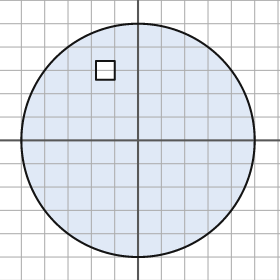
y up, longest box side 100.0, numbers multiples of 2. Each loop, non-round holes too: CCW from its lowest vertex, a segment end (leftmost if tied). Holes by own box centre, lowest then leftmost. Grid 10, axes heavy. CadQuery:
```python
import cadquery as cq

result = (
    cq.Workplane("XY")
    .moveTo(0.0, 0.0)
    .circle(50.0)
    .moveTo(-18.0, 26.0)
    .lineTo(-10.0, 26.0)
    .lineTo(-10.0, 34.0)
    .lineTo(-18.0, 34.0)
    .close()
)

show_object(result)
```